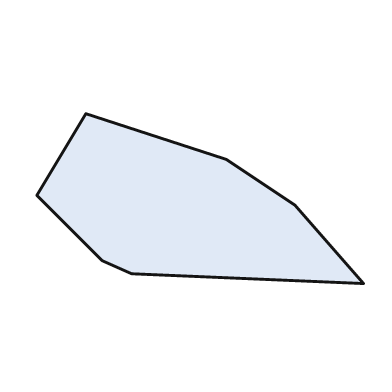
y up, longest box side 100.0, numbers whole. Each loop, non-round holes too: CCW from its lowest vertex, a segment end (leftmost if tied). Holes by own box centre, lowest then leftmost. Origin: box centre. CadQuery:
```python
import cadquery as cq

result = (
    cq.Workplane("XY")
    .moveTo(50.0, -26.0)
    .lineTo(29.0, -2.0)
    .lineTo(8.0, 12.0)
    .lineTo(-35.0, 26.0)
    .lineTo(-50.0, 1.0)
    .lineTo(-30.0, -19.0)
    .lineTo(-21.0, -23.0)
    .close()
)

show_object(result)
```